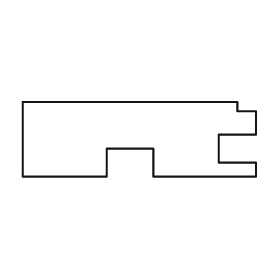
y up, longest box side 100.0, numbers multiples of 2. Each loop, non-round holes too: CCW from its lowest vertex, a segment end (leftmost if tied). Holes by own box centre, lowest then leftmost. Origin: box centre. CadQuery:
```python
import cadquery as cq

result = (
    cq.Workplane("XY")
    .moveTo(-50.0, -16.0)
    .lineTo(-14.0, -16.0)
    .lineTo(-14.0, -4.0)
    .lineTo(6.0, -4.0)
    .lineTo(6.0, -16.0)
    .lineTo(50.0, -16.0)
    .lineTo(50.0, -10.0)
    .lineTo(34.0, -10.0)
    .lineTo(34.0, 2.0)
    .lineTo(50.0, 2.0)
    .lineTo(50.0, 12.0)
    .lineTo(42.0, 12.0)
    .lineTo(42.0, 16.0)
    .lineTo(-50.0, 16.0)
    .close()
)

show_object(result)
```